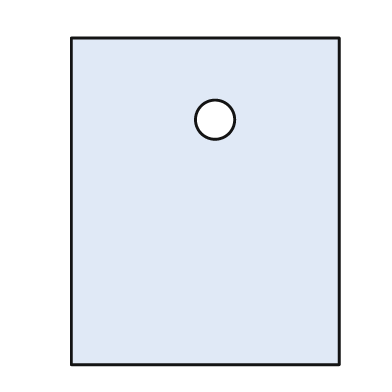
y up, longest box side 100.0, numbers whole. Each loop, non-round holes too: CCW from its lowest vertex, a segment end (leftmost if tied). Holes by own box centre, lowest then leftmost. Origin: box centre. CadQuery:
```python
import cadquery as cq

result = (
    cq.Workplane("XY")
    .moveTo(-41.0, -50.0)
    .lineTo(41.0, -50.0)
    .lineTo(41.0, 50.0)
    .lineTo(-41.0, 50.0)
    .close()
    .moveTo(3.0, 25.0)
    .circle(6.0)
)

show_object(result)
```